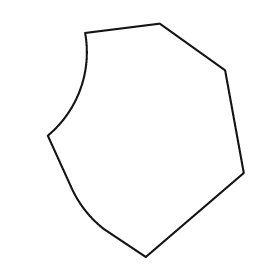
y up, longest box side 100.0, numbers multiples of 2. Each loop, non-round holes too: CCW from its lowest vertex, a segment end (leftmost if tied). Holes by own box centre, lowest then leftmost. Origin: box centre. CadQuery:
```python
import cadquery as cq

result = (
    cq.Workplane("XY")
    .moveTo(0.0, -50.0)
    .lineTo(42.0, -14.0)
    .lineTo(34.0, 30.0)
    .lineTo(6.0, 50.0)
    .lineTo(-26.0, 46.0)
    .threePointArc((-28.0, 22.0), (-42.0, 2.0))
    .lineTo(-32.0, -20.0)
    .threePointArc((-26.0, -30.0), (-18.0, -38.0))
    .close()
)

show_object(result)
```